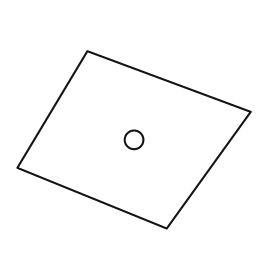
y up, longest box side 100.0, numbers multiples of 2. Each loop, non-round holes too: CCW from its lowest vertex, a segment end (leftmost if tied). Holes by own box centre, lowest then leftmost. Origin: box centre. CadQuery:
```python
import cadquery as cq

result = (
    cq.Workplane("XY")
    .moveTo(14.0, -38.0)
    .lineTo(50.0, 12.0)
    .lineTo(-20.0, 38.0)
    .lineTo(-50.0, -12.0)
    .close()
    .moveTo(0.0, 0.0)
    .circle(4.0)
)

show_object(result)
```